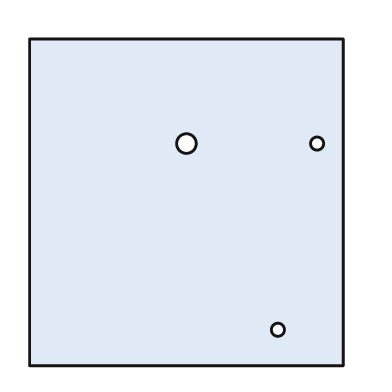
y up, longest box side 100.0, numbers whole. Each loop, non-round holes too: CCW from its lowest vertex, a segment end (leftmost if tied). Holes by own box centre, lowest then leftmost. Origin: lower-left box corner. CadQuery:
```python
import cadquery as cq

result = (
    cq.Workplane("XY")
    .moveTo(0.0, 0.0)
    .lineTo(96.0, 0.0)
    .lineTo(96.0, 100.0)
    .lineTo(0.0, 100.0)
    .close()
    .moveTo(76.0, 11.0)
    .circle(2.0)
    .moveTo(48.0, 68.0)
    .circle(3.0)
    .moveTo(88.0, 68.0)
    .circle(2.0)
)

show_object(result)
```